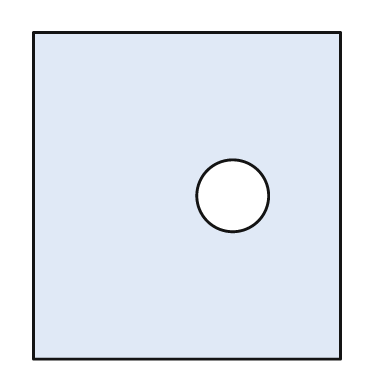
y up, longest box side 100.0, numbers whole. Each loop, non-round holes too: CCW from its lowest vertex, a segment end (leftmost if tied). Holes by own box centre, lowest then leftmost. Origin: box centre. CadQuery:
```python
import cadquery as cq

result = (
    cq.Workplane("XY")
    .moveTo(-47.0, -50.0)
    .lineTo(47.0, -50.0)
    .lineTo(47.0, 50.0)
    .lineTo(-47.0, 50.0)
    .close()
    .moveTo(14.0, 0.0)
    .circle(11.0)
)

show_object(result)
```